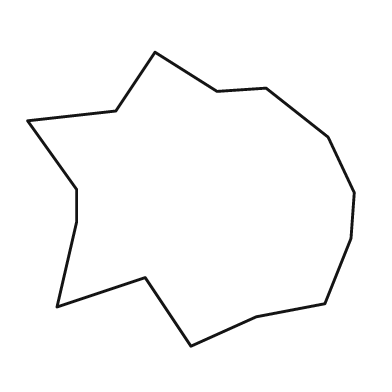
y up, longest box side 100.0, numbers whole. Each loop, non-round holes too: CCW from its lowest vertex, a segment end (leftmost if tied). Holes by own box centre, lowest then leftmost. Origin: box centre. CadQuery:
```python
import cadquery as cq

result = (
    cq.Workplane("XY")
    .moveTo(0.0, -45.0)
    .lineTo(20.0, -36.0)
    .lineTo(41.0, -32.0)
    .lineTo(49.0, -12.0)
    .lineTo(50.0, 2.0)
    .lineTo(42.0, 19.0)
    .lineTo(23.0, 34.0)
    .lineTo(8.0, 33.0)
    .lineTo(-11.0, 45.0)
    .lineTo(-23.0, 27.0)
    .lineTo(-50.0, 24.0)
    .lineTo(-35.0, 3.0)
    .lineTo(-35.0, -7.0)
    .lineTo(-41.0, -33.0)
    .lineTo(-14.0, -24.0)
    .close()
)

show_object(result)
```